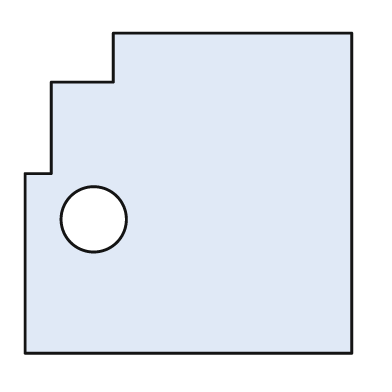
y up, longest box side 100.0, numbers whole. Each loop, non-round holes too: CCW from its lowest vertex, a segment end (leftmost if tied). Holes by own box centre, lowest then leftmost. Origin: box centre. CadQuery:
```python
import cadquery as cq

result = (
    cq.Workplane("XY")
    .moveTo(-50.0, -49.0)
    .lineTo(50.0, -49.0)
    .lineTo(50.0, 49.0)
    .lineTo(-23.0, 49.0)
    .lineTo(-23.0, 34.0)
    .lineTo(-42.0, 34.0)
    .lineTo(-42.0, 6.0)
    .lineTo(-50.0, 6.0)
    .close()
    .moveTo(-29.0, -8.0)
    .circle(10.0)
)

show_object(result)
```